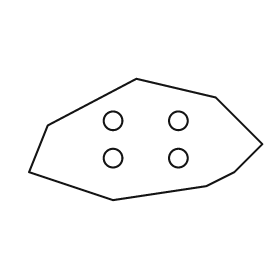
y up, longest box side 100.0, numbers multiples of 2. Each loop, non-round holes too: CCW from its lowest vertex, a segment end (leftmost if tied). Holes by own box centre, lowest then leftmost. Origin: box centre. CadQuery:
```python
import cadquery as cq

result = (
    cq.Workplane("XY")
    .moveTo(-14.0, -26.0)
    .lineTo(26.0, -20.0)
    .lineTo(38.0, -14.0)
    .lineTo(50.0, -2.0)
    .lineTo(30.0, 18.0)
    .lineTo(-4.0, 26.0)
    .lineTo(-42.0, 6.0)
    .lineTo(-50.0, -14.0)
    .close()
    .moveTo(-14.0, -8.0)
    .circle(4.0)
    .moveTo(14.0, -8.0)
    .circle(4.0)
    .moveTo(-14.0, 8.0)
    .circle(4.0)
    .moveTo(14.0, 8.0)
    .circle(4.0)
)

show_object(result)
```